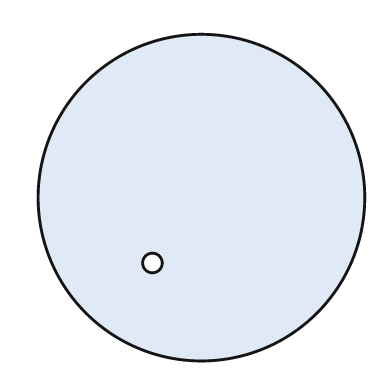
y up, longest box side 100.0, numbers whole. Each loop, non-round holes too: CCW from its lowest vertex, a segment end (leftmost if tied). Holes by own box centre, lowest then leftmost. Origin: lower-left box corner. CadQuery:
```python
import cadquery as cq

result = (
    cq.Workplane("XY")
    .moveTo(50.0, 50.0)
    .circle(50.0)
    .moveTo(35.0, 30.0)
    .circle(3.0)
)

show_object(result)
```